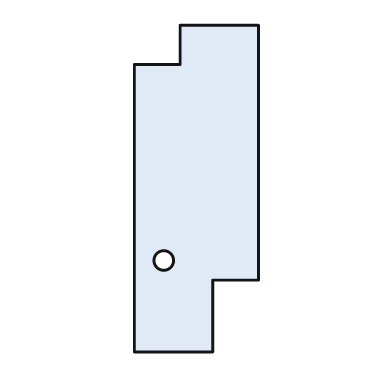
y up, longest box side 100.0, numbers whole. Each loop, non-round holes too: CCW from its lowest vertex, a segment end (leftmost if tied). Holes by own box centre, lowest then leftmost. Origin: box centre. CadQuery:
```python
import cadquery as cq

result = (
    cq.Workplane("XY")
    .moveTo(-19.0, -50.0)
    .lineTo(5.0, -50.0)
    .lineTo(5.0, -28.0)
    .lineTo(19.0, -28.0)
    .lineTo(19.0, 50.0)
    .lineTo(-5.0, 50.0)
    .lineTo(-5.0, 38.0)
    .lineTo(-19.0, 38.0)
    .close()
    .moveTo(-10.0, -22.0)
    .circle(3.0)
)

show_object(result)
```